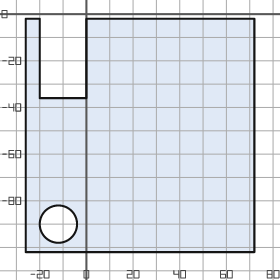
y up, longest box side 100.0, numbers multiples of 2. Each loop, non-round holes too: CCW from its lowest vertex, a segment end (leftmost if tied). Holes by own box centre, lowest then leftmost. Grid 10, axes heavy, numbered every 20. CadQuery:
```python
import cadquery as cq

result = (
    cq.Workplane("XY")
    .moveTo(-26.0, -102.0)
    .lineTo(72.0, -102.0)
    .lineTo(72.0, -2.0)
    .lineTo(0.0, -2.0)
    .lineTo(0.0, -36.0)
    .lineTo(-20.0, -36.0)
    .lineTo(-20.0, -2.0)
    .lineTo(-26.0, -2.0)
    .close()
    .moveTo(-12.0, -90.0)
    .circle(8.0)
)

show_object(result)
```